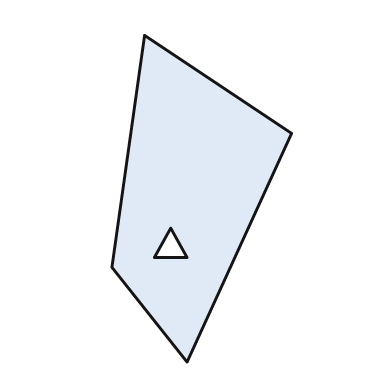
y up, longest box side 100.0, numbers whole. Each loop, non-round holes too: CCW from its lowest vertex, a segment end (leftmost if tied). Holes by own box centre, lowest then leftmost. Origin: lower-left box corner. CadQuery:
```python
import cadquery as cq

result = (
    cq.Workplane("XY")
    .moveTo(23.0, 0.0)
    .lineTo(55.0, 70.0)
    .lineTo(10.0, 100.0)
    .lineTo(0.0, 29.0)
    .close()
    .moveTo(13.0, 32.0)
    .lineTo(23.0, 32.0)
    .lineTo(18.0, 41.0)
    .close()
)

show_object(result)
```